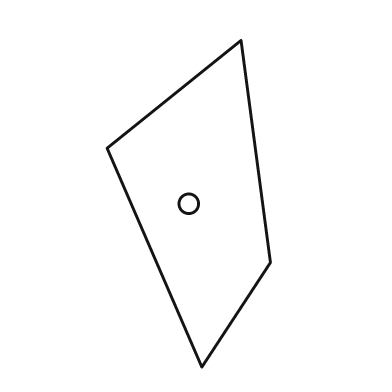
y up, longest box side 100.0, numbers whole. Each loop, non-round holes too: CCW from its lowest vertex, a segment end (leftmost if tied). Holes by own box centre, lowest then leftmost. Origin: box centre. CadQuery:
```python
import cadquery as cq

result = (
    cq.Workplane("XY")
    .moveTo(4.0, -50.0)
    .lineTo(25.0, -18.0)
    .lineTo(16.0, 50.0)
    .lineTo(-25.0, 17.0)
    .close()
    .moveTo(0.0, 0.0)
    .circle(3.0)
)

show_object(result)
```